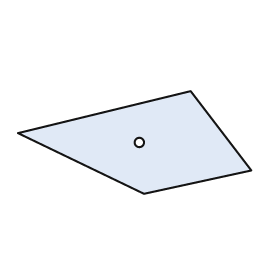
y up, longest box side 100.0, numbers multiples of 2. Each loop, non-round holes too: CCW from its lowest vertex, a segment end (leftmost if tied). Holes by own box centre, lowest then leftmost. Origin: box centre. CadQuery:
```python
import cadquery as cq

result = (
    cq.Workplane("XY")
    .moveTo(4.0, -22.0)
    .lineTo(50.0, -12.0)
    .lineTo(24.0, 22.0)
    .lineTo(-50.0, 4.0)
    .close()
    .moveTo(2.0, 0.0)
    .circle(2.0)
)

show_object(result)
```